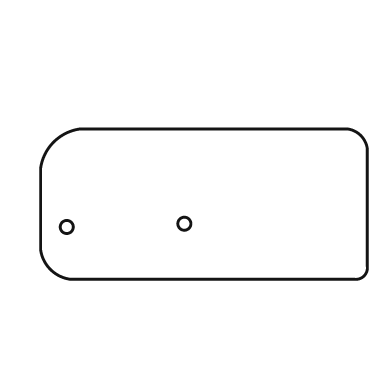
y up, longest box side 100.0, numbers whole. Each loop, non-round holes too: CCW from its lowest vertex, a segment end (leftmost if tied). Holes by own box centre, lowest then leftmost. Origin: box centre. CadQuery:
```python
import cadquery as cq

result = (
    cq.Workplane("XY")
    .moveTo(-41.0, -23.0)
    .lineTo(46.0, -23.0)
    .threePointArc((49.0, -22.0), (50.0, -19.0))
    .lineTo(50.0, 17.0)
    .threePointArc((48.0, 21.0), (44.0, 23.0))
    .lineTo(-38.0, 23.0)
    .threePointArc((-46.0, 19.0), (-50.0, 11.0))
    .lineTo(-50.0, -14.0)
    .threePointArc((-47.0, -20.0), (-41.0, -23.0))
    .close()
    .moveTo(-42.0, -7.0)
    .circle(2.0)
    .moveTo(-6.0, -6.0)
    .circle(2.0)
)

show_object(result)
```